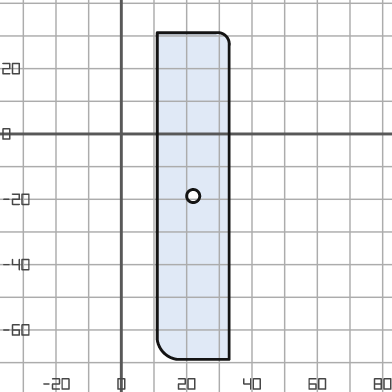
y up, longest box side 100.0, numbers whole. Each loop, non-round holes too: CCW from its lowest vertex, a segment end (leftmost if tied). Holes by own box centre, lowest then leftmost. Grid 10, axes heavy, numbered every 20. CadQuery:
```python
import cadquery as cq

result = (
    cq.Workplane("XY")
    .moveTo(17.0, -69.0)
    .lineTo(33.0, -69.0)
    .lineTo(33.0, 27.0)
    .threePointArc((32.0, 30.0), (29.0, 31.0))
    .lineTo(11.0, 31.0)
    .lineTo(11.0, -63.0)
    .threePointArc((13.0, -67.0), (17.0, -69.0))
    .close()
    .moveTo(22.0, -19.0)
    .circle(2.0)
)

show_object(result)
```